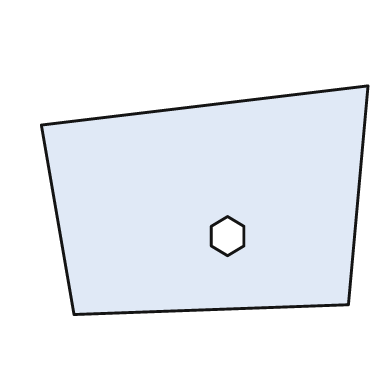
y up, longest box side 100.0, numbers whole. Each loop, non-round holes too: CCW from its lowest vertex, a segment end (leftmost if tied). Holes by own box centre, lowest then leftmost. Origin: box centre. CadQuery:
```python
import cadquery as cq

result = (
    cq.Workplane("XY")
    .moveTo(-40.0, -35.0)
    .lineTo(44.0, -32.0)
    .lineTo(50.0, 35.0)
    .lineTo(-50.0, 23.0)
    .close()
    .moveTo(7.0, -17.0)
    .lineTo(12.0, -14.0)
    .lineTo(12.0, -8.0)
    .lineTo(7.0, -5.0)
    .lineTo(2.0, -8.0)
    .lineTo(2.0, -14.0)
    .close()
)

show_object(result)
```